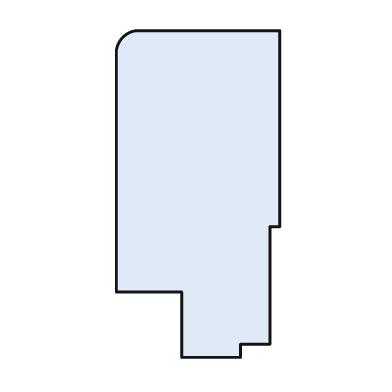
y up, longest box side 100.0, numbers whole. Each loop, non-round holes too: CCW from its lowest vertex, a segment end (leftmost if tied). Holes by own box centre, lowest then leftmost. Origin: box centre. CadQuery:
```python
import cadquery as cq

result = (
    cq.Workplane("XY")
    .moveTo(-5.0, -50.0)
    .lineTo(13.0, -50.0)
    .lineTo(13.0, -46.0)
    .lineTo(22.0, -46.0)
    .lineTo(22.0, -10.0)
    .lineTo(25.0, -10.0)
    .lineTo(25.0, 50.0)
    .lineTo(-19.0, 50.0)
    .threePointArc((-23.0, 48.0), (-25.0, 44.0))
    .lineTo(-25.0, -30.0)
    .lineTo(-5.0, -30.0)
    .close()
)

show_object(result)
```